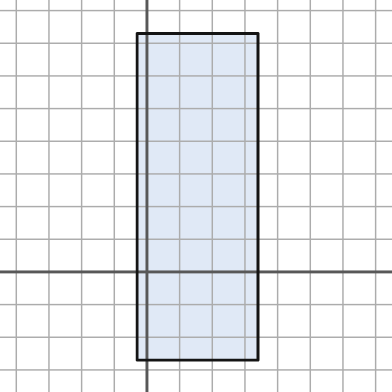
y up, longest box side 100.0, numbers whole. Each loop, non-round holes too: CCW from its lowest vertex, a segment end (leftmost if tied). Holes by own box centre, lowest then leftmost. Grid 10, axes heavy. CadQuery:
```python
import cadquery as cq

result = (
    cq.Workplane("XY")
    .moveTo(-3.0, -27.0)
    .lineTo(34.0, -27.0)
    .lineTo(34.0, 73.0)
    .lineTo(-3.0, 73.0)
    .close()
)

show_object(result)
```